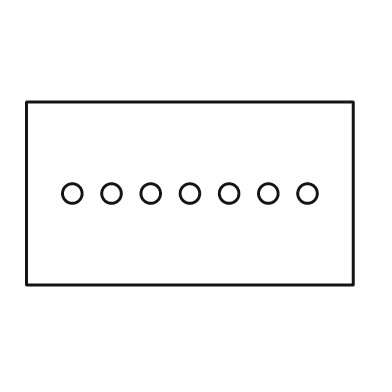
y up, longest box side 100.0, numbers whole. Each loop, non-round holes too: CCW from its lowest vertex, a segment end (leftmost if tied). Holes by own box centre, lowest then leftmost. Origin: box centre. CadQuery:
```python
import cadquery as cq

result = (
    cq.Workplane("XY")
    .moveTo(-50.0, -28.0)
    .lineTo(50.0, -28.0)
    .lineTo(50.0, 28.0)
    .lineTo(-50.0, 28.0)
    .close()
    .moveTo(-36.0, 0.0)
    .circle(3.0)
    .moveTo(-24.0, 0.0)
    .circle(3.0)
    .moveTo(-12.0, 0.0)
    .circle(3.0)
    .moveTo(0.0, 0.0)
    .circle(3.0)
    .moveTo(12.0, 0.0)
    .circle(3.0)
    .moveTo(24.0, 0.0)
    .circle(3.0)
    .moveTo(36.0, 0.0)
    .circle(3.0)
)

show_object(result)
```